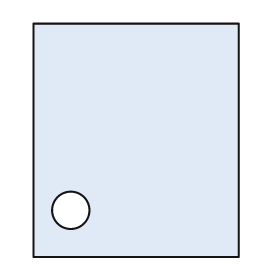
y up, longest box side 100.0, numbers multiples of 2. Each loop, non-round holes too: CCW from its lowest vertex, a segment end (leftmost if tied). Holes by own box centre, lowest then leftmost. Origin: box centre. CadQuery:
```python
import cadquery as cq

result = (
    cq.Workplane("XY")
    .moveTo(-44.0, -50.0)
    .lineTo(44.0, -50.0)
    .lineTo(44.0, 50.0)
    .lineTo(-44.0, 50.0)
    .close()
    .moveTo(-28.0, -30.0)
    .circle(8.0)
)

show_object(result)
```